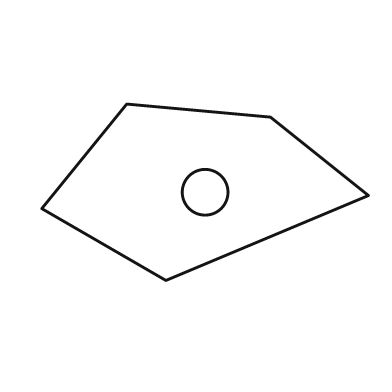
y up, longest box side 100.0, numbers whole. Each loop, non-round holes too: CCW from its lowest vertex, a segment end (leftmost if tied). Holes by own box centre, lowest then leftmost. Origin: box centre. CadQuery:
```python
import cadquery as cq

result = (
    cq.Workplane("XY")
    .moveTo(-12.0, -27.0)
    .lineTo(50.0, -1.0)
    .lineTo(20.0, 23.0)
    .lineTo(-24.0, 27.0)
    .lineTo(-50.0, -5.0)
    .close()
    .moveTo(0.0, 0.0)
    .circle(7.0)
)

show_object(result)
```